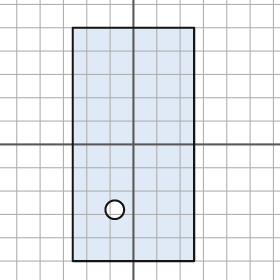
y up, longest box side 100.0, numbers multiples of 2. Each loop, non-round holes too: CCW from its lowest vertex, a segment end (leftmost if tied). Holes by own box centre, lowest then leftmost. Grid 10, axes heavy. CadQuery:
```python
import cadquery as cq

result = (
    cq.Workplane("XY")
    .moveTo(-26.0, -50.0)
    .lineTo(26.0, -50.0)
    .lineTo(26.0, 50.0)
    .lineTo(-26.0, 50.0)
    .close()
    .moveTo(-8.0, -28.0)
    .circle(4.0)
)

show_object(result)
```